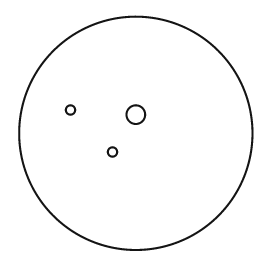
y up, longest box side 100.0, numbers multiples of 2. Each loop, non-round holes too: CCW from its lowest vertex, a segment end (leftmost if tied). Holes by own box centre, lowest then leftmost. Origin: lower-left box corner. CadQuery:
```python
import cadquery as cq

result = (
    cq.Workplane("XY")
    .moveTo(50.0, 50.0)
    .circle(50.0)
    .moveTo(40.0, 42.0)
    .circle(2.0)
    .moveTo(50.0, 58.0)
    .circle(4.0)
    .moveTo(22.0, 60.0)
    .circle(2.0)
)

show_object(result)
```